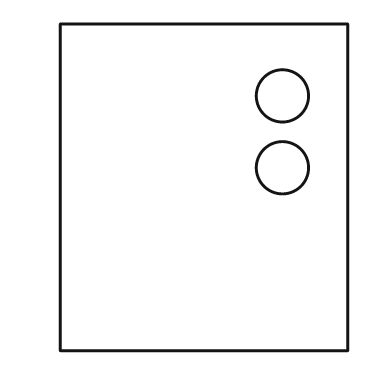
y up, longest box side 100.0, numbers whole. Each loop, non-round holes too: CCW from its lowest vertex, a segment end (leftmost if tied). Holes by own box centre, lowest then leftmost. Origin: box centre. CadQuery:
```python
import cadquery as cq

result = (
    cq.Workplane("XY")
    .moveTo(-44.0, -50.0)
    .lineTo(44.0, -50.0)
    .lineTo(44.0, 50.0)
    .lineTo(-44.0, 50.0)
    .close()
    .moveTo(24.0, 6.0)
    .circle(8.0)
    .moveTo(24.0, 28.0)
    .circle(8.0)
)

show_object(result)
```